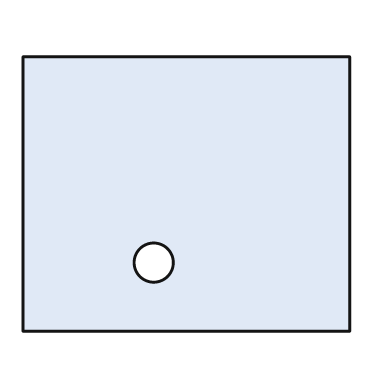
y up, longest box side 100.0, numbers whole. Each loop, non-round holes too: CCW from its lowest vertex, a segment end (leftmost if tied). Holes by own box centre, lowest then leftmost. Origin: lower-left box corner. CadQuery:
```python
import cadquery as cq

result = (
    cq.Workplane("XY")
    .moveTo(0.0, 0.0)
    .lineTo(100.0, 0.0)
    .lineTo(100.0, 84.0)
    .lineTo(0.0, 84.0)
    .close()
    .moveTo(40.0, 21.0)
    .circle(6.0)
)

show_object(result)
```